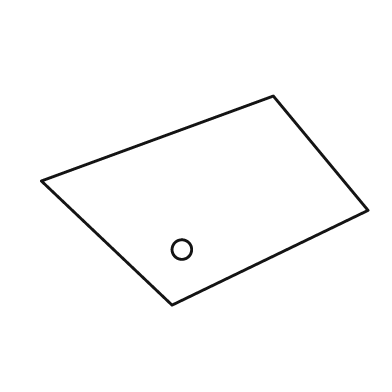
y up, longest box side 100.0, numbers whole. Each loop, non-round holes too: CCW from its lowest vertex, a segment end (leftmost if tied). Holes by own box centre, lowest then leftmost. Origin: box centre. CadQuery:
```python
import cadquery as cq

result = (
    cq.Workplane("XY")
    .moveTo(-10.0, -32.0)
    .lineTo(50.0, -3.0)
    .lineTo(21.0, 32.0)
    .lineTo(-50.0, 6.0)
    .close()
    .moveTo(-7.0, -15.0)
    .circle(3.0)
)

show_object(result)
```